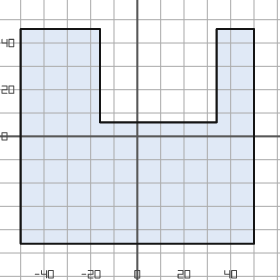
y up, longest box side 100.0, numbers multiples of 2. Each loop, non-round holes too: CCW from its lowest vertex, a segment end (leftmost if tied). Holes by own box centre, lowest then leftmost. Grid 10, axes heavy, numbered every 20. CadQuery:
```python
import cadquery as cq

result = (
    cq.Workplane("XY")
    .moveTo(-50.0, -46.0)
    .lineTo(50.0, -46.0)
    .lineTo(50.0, 46.0)
    .lineTo(34.0, 46.0)
    .lineTo(34.0, 6.0)
    .lineTo(-16.0, 6.0)
    .lineTo(-16.0, 46.0)
    .lineTo(-50.0, 46.0)
    .close()
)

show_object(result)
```